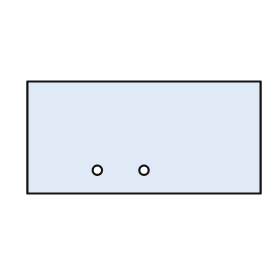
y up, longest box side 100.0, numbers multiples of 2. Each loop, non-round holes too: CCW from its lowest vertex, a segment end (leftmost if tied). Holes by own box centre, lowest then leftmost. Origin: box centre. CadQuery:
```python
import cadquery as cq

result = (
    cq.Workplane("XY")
    .moveTo(-50.0, -24.0)
    .lineTo(50.0, -24.0)
    .lineTo(50.0, 24.0)
    .lineTo(-50.0, 24.0)
    .close()
    .moveTo(-20.0, -14.0)
    .circle(2.0)
    .moveTo(0.0, -14.0)
    .circle(2.0)
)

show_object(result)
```